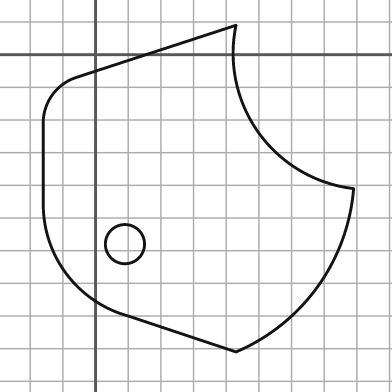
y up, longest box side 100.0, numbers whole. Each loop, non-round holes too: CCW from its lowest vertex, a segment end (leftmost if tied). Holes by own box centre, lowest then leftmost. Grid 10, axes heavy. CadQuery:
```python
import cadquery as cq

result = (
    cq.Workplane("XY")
    .moveTo(43.0, -91.0)
    .threePointArc((68.0, -71.0), (79.0, -41.0))
    .threePointArc((50.0, -24.0), (43.0, 9.0))
    .lineTo(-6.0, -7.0)
    .threePointArc((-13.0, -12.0), (-16.0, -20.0))
    .lineTo(-16.0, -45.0)
    .threePointArc((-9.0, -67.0), (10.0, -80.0))
    .close()
    .moveTo(9.0, -58.0)
    .circle(6.0)
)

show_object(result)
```